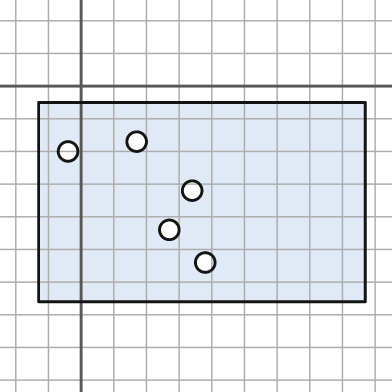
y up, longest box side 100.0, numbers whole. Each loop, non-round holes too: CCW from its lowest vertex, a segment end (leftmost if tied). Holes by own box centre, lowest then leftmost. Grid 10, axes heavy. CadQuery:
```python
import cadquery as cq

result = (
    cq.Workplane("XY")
    .moveTo(-13.0, -66.0)
    .lineTo(87.0, -66.0)
    .lineTo(87.0, -5.0)
    .lineTo(-13.0, -5.0)
    .close()
    .moveTo(38.0, -54.0)
    .circle(3.0)
    .moveTo(27.0, -44.0)
    .circle(3.0)
    .moveTo(34.0, -32.0)
    .circle(3.0)
    .moveTo(-4.0, -20.0)
    .circle(3.0)
    .moveTo(17.0, -17.0)
    .circle(3.0)
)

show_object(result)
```